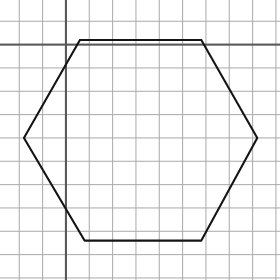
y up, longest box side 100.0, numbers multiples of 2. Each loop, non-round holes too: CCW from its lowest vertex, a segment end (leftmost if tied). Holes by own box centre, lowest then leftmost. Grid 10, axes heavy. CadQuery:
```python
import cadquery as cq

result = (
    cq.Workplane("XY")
    .moveTo(8.0, -84.0)
    .lineTo(58.0, -84.0)
    .lineTo(82.0, -40.0)
    .lineTo(58.0, 2.0)
    .lineTo(6.0, 2.0)
    .lineTo(-18.0, -40.0)
    .close()
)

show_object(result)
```